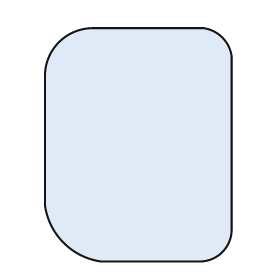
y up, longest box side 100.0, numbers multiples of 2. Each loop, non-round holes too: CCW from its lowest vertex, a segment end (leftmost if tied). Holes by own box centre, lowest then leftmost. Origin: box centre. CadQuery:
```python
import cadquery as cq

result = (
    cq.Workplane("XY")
    .moveTo(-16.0, -50.0)
    .lineTo(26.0, -50.0)
    .threePointArc((36.0, -46.0), (40.0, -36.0))
    .lineTo(40.0, 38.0)
    .threePointArc((36.0, 46.0), (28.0, 50.0))
    .lineTo(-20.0, 50.0)
    .threePointArc((-34.0, 44.0), (-40.0, 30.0))
    .lineTo(-40.0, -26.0)
    .threePointArc((-32.0, -42.0), (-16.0, -50.0))
    .close()
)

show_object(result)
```